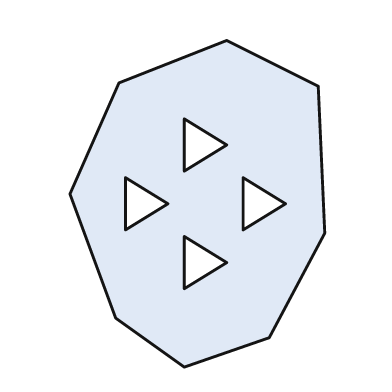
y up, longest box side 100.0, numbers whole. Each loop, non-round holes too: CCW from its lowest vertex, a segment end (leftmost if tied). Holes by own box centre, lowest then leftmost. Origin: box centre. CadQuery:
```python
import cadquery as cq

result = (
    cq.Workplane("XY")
    .moveTo(-4.0, -50.0)
    .lineTo(22.0, -41.0)
    .lineTo(39.0, -9.0)
    .lineTo(37.0, 36.0)
    .lineTo(9.0, 50.0)
    .lineTo(-24.0, 37.0)
    .lineTo(-39.0, 3.0)
    .lineTo(-25.0, -35.0)
    .close()
    .moveTo(-4.0, -26.0)
    .lineTo(9.0, -18.0)
    .lineTo(-4.0, -10.0)
    .close()
    .moveTo(-22.0, -8.0)
    .lineTo(-9.0, 0.0)
    .lineTo(-22.0, 8.0)
    .close()
    .moveTo(14.0, -8.0)
    .lineTo(27.0, 0.0)
    .lineTo(14.0, 8.0)
    .close()
    .moveTo(-4.0, 10.0)
    .lineTo(9.0, 18.0)
    .lineTo(-4.0, 26.0)
    .close()
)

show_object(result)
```